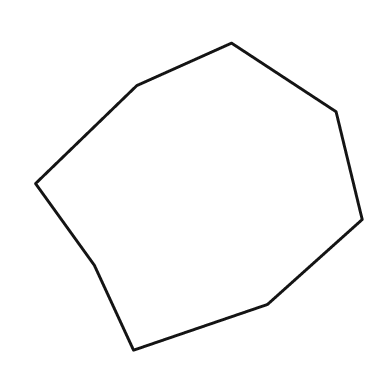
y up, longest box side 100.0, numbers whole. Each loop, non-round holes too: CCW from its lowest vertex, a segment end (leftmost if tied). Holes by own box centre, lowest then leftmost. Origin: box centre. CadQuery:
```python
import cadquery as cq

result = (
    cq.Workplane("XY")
    .moveTo(-20.0, -47.0)
    .lineTo(21.0, -33.0)
    .lineTo(50.0, -7.0)
    .lineTo(42.0, 26.0)
    .lineTo(10.0, 47.0)
    .lineTo(-19.0, 34.0)
    .lineTo(-50.0, 4.0)
    .lineTo(-32.0, -21.0)
    .close()
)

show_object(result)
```